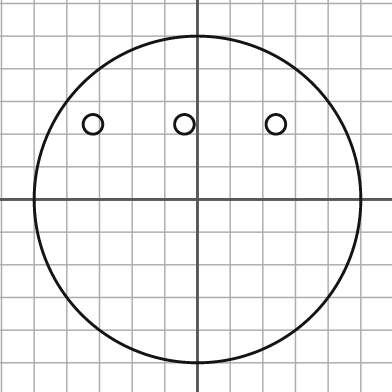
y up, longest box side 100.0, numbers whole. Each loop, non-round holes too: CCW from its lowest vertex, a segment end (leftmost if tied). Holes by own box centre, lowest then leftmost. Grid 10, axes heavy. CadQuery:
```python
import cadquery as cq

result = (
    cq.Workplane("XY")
    .moveTo(0.0, 0.0)
    .circle(50.0)
    .moveTo(-32.0, 23.0)
    .circle(3.0)
    .moveTo(-4.0, 23.0)
    .circle(3.0)
    .moveTo(24.0, 23.0)
    .circle(3.0)
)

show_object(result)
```